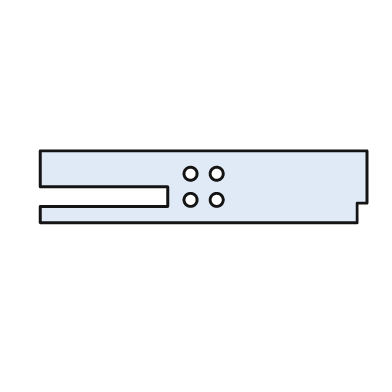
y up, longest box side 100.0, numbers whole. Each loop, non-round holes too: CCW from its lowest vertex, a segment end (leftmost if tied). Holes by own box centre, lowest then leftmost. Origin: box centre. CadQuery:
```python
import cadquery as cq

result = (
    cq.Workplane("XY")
    .moveTo(-50.0, -11.0)
    .lineTo(47.0, -11.0)
    .lineTo(47.0, -5.0)
    .lineTo(50.0, -5.0)
    .lineTo(50.0, 11.0)
    .lineTo(-50.0, 11.0)
    .lineTo(-50.0, 0.0)
    .lineTo(-11.0, 0.0)
    .lineTo(-11.0, -6.0)
    .lineTo(-50.0, -6.0)
    .close()
    .moveTo(-4.0, -4.0)
    .circle(2.0)
    .moveTo(4.0, -4.0)
    .circle(2.0)
    .moveTo(-4.0, 4.0)
    .circle(2.0)
    .moveTo(4.0, 4.0)
    .circle(2.0)
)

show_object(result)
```